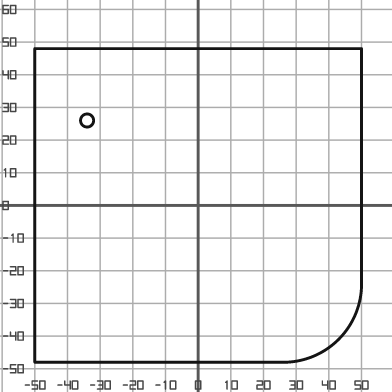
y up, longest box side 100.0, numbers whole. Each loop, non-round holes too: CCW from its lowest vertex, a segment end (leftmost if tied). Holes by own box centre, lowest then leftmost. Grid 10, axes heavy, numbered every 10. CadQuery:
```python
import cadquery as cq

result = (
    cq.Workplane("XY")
    .moveTo(-50.0, -48.0)
    .lineTo(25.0, -48.0)
    .threePointArc((43.0, -41.0), (50.0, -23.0))
    .lineTo(50.0, 48.0)
    .lineTo(-50.0, 48.0)
    .close()
    .moveTo(-34.0, 26.0)
    .circle(2.0)
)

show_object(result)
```